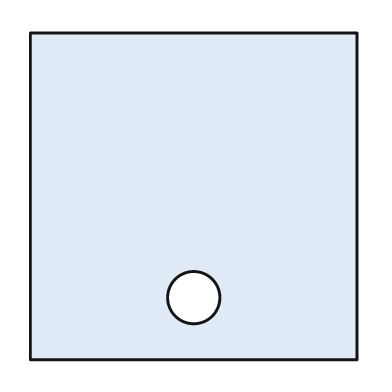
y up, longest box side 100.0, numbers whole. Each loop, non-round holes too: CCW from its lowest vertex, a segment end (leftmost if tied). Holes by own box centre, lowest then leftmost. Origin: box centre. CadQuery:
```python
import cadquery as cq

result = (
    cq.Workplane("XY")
    .moveTo(-50.0, -50.0)
    .lineTo(50.0, -50.0)
    .lineTo(50.0, 50.0)
    .lineTo(-50.0, 50.0)
    .close()
    .moveTo(0.0, -31.0)
    .circle(8.0)
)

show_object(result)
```